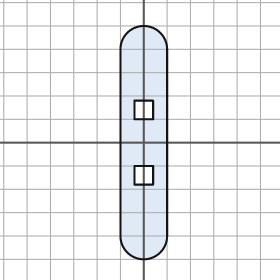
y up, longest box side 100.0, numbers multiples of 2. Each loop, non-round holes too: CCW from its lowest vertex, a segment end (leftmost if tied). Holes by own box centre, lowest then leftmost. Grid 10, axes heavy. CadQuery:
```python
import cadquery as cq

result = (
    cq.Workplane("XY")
    .moveTo(-10.0, -40.0)
    .threePointArc((0.0, -50.0), (10.0, -40.0))
    .lineTo(10.0, 40.0)
    .threePointArc((0.0, 50.0), (-10.0, 40.0))
    .close()
    .moveTo(-4.0, -18.0)
    .lineTo(4.0, -18.0)
    .lineTo(4.0, -10.0)
    .lineTo(-4.0, -10.0)
    .close()
    .moveTo(-4.0, 10.0)
    .lineTo(4.0, 10.0)
    .lineTo(4.0, 18.0)
    .lineTo(-4.0, 18.0)
    .close()
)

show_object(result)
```